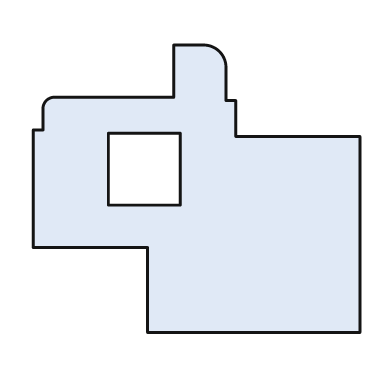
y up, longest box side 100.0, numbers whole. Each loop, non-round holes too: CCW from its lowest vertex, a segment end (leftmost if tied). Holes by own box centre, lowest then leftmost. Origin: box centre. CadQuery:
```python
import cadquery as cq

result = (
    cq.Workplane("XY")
    .moveTo(-15.0, -44.0)
    .lineTo(50.0, -44.0)
    .lineTo(50.0, 16.0)
    .lineTo(12.0, 16.0)
    .lineTo(12.0, 27.0)
    .lineTo(9.0, 27.0)
    .lineTo(9.0, 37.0)
    .threePointArc((7.0, 42.0), (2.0, 44.0))
    .lineTo(-7.0, 44.0)
    .lineTo(-7.0, 28.0)
    .lineTo(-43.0, 28.0)
    .threePointArc((-46.0, 27.0), (-47.0, 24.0))
    .lineTo(-47.0, 18.0)
    .lineTo(-50.0, 18.0)
    .lineTo(-50.0, -18.0)
    .lineTo(-15.0, -18.0)
    .close()
    .moveTo(-27.0, -5.0)
    .lineTo(-5.0, -5.0)
    .lineTo(-5.0, 17.0)
    .lineTo(-27.0, 17.0)
    .close()
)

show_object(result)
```